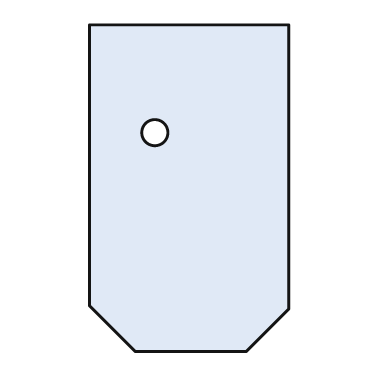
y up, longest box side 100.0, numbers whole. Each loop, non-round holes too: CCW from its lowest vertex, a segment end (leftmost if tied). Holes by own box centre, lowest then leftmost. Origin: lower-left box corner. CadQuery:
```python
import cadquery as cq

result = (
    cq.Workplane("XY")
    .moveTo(14.0, 0.0)
    .lineTo(48.0, 0.0)
    .lineTo(61.0, 13.0)
    .lineTo(61.0, 100.0)
    .lineTo(0.0, 100.0)
    .lineTo(0.0, 14.0)
    .close()
    .moveTo(20.0, 67.0)
    .circle(4.0)
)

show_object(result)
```